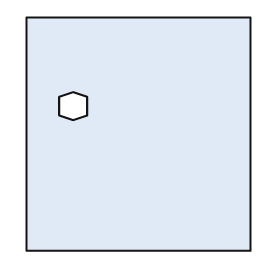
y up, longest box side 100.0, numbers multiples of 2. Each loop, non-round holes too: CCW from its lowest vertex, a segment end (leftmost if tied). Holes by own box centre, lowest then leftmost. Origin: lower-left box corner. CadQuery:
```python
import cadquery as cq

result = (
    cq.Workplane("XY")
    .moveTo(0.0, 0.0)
    .lineTo(96.0, 0.0)
    .lineTo(96.0, 100.0)
    .lineTo(0.0, 100.0)
    .close()
    .moveTo(20.0, 56.0)
    .lineTo(26.0, 58.0)
    .lineTo(26.0, 66.0)
    .lineTo(20.0, 68.0)
    .lineTo(14.0, 66.0)
    .lineTo(14.0, 58.0)
    .close()
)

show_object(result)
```